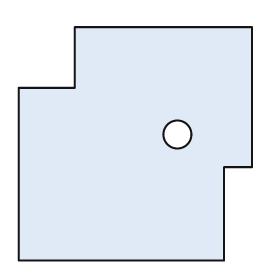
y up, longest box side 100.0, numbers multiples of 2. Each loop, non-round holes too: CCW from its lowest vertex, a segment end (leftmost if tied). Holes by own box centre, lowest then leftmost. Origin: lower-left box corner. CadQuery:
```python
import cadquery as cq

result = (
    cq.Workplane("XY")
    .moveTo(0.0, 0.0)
    .lineTo(88.0, 0.0)
    .lineTo(88.0, 40.0)
    .lineTo(100.0, 40.0)
    .lineTo(100.0, 100.0)
    .lineTo(24.0, 100.0)
    .lineTo(24.0, 74.0)
    .lineTo(0.0, 74.0)
    .close()
    .moveTo(68.0, 54.0)
    .circle(6.0)
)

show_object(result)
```